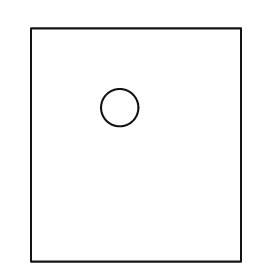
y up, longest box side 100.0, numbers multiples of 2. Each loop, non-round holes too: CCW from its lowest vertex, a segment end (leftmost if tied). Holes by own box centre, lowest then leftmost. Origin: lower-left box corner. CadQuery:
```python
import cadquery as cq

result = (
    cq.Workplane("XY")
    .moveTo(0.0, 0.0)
    .lineTo(90.0, 0.0)
    .lineTo(90.0, 100.0)
    .lineTo(0.0, 100.0)
    .close()
    .moveTo(38.0, 66.0)
    .circle(8.0)
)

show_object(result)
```